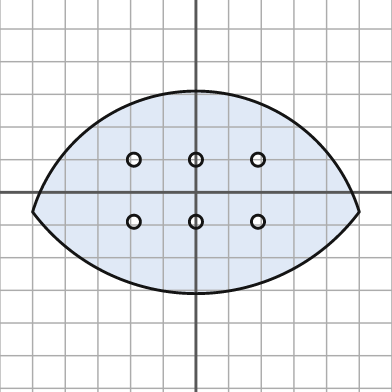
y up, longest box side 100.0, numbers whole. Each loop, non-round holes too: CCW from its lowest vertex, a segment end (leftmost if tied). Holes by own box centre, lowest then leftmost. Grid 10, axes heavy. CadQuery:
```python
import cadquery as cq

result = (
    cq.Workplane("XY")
    .moveTo(-50.0, -6.0)
    .threePointArc((0.0, -31.0), (50.0, -6.0))
    .threePointArc((0.0, 31.0), (-50.0, -6.0))
    .close()
    .moveTo(-19.0, -9.0)
    .circle(2.0)
    .moveTo(0.0, -9.0)
    .circle(2.0)
    .moveTo(19.0, -9.0)
    .circle(2.0)
    .moveTo(-19.0, 10.0)
    .circle(2.0)
    .moveTo(0.0, 10.0)
    .circle(2.0)
    .moveTo(19.0, 10.0)
    .circle(2.0)
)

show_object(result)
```